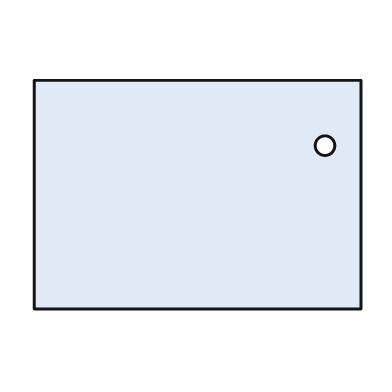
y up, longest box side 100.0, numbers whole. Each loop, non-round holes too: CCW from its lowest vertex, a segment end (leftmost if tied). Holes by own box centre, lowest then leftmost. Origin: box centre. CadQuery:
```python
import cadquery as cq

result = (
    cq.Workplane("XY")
    .moveTo(-50.0, -35.0)
    .lineTo(50.0, -35.0)
    .lineTo(50.0, 35.0)
    .lineTo(-50.0, 35.0)
    .close()
    .moveTo(39.0, 15.0)
    .circle(3.0)
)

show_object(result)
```